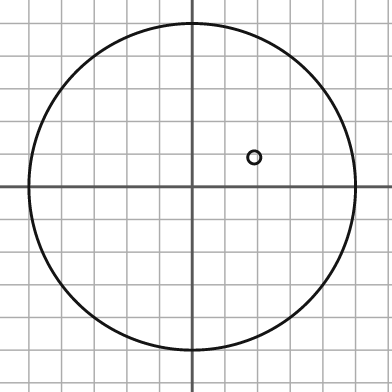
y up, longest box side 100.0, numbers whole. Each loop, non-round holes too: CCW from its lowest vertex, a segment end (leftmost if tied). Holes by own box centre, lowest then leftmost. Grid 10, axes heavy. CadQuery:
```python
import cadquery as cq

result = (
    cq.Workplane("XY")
    .moveTo(0.0, 0.0)
    .circle(50.0)
    .moveTo(19.0, 9.0)
    .circle(2.0)
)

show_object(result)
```